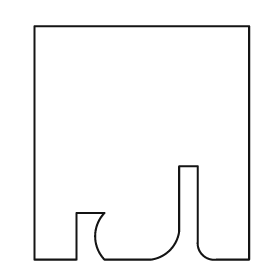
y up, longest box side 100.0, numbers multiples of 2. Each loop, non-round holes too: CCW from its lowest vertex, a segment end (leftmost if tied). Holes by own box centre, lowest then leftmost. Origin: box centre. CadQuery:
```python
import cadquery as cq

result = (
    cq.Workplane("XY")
    .moveTo(-46.0, -50.0)
    .lineTo(-28.0, -50.0)
    .lineTo(-28.0, -30.0)
    .lineTo(-16.0, -30.0)
    .threePointArc((-20.0, -40.0), (-16.0, -50.0))
    .lineTo(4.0, -50.0)
    .threePointArc((12.0, -46.0), (16.0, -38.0))
    .lineTo(16.0, -10.0)
    .lineTo(24.0, -10.0)
    .lineTo(24.0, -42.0)
    .threePointArc((26.0, -48.0), (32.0, -50.0))
    .lineTo(46.0, -50.0)
    .lineTo(46.0, 50.0)
    .lineTo(-46.0, 50.0)
    .close()
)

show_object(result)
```